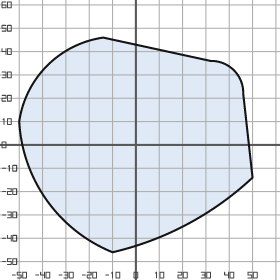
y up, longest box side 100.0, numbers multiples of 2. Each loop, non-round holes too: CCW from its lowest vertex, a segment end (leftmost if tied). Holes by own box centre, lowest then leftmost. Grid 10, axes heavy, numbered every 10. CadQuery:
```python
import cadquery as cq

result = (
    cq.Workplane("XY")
    .moveTo(-10.0, -46.0)
    .threePointArc((22.0, -34.0), (50.0, -14.0))
    .lineTo(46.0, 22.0)
    .threePointArc((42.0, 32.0), (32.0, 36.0))
    .lineTo(-14.0, 46.0)
    .threePointArc((-38.0, 34.0), (-50.0, 10.0))
    .threePointArc((-38.0, -24.0), (-10.0, -46.0))
    .close()
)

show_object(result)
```